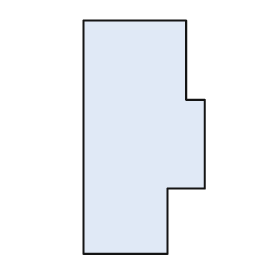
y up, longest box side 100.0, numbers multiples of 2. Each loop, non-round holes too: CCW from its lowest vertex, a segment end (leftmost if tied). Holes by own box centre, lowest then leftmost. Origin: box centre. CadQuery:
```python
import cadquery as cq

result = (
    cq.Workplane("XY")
    .moveTo(-26.0, -50.0)
    .lineTo(10.0, -50.0)
    .lineTo(10.0, -22.0)
    .lineTo(26.0, -22.0)
    .lineTo(26.0, 16.0)
    .lineTo(18.0, 16.0)
    .lineTo(18.0, 50.0)
    .lineTo(-26.0, 50.0)
    .close()
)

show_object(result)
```